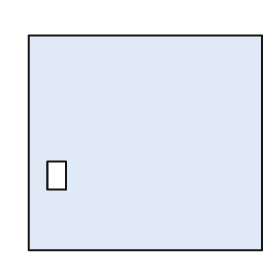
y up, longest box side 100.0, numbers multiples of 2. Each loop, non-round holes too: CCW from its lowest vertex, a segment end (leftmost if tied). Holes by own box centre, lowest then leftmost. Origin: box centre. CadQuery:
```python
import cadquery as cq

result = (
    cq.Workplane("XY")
    .moveTo(-50.0, -46.0)
    .lineTo(50.0, -46.0)
    .lineTo(50.0, 46.0)
    .lineTo(-50.0, 46.0)
    .close()
    .moveTo(-42.0, -20.0)
    .lineTo(-34.0, -20.0)
    .lineTo(-34.0, -8.0)
    .lineTo(-42.0, -8.0)
    .close()
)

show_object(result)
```